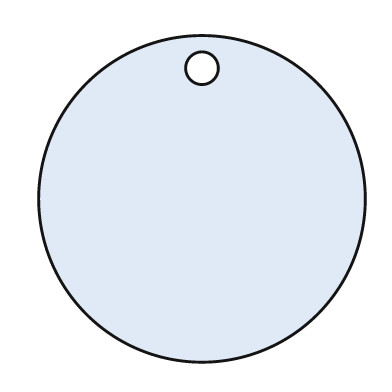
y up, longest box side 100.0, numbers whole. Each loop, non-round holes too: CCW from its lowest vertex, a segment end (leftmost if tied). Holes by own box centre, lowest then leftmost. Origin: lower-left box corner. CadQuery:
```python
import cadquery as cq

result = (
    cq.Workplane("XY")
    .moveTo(50.0, 50.0)
    .circle(50.0)
    .moveTo(50.0, 90.0)
    .circle(5.0)
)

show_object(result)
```